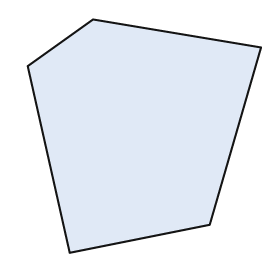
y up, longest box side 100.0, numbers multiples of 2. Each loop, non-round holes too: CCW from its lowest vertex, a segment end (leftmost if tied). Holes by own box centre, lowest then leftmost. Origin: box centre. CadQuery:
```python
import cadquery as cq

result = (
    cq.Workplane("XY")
    .moveTo(-32.0, -50.0)
    .lineTo(28.0, -38.0)
    .lineTo(50.0, 38.0)
    .lineTo(-22.0, 50.0)
    .lineTo(-50.0, 30.0)
    .close()
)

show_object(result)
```